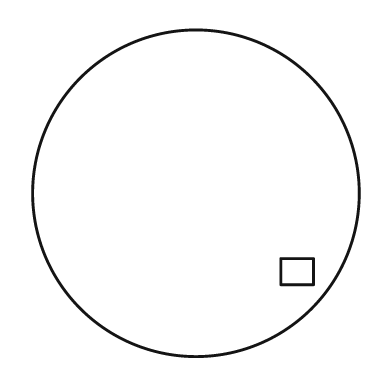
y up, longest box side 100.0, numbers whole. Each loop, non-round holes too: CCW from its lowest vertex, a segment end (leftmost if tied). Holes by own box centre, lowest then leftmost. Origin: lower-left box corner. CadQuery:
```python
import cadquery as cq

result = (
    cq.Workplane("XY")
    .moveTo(50.0, 50.0)
    .circle(50.0)
    .moveTo(76.0, 22.0)
    .lineTo(86.0, 22.0)
    .lineTo(86.0, 30.0)
    .lineTo(76.0, 30.0)
    .close()
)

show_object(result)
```